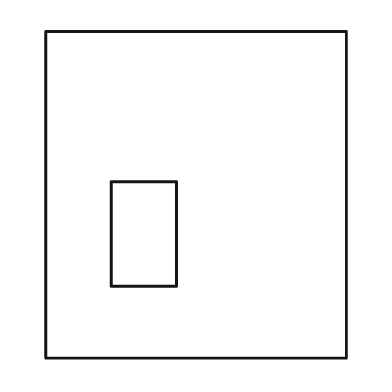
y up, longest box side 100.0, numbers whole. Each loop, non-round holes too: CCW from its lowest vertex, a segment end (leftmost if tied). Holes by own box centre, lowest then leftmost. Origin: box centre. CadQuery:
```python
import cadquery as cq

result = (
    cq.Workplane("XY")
    .moveTo(-46.0, -50.0)
    .lineTo(46.0, -50.0)
    .lineTo(46.0, 50.0)
    .lineTo(-46.0, 50.0)
    .close()
    .moveTo(-26.0, -28.0)
    .lineTo(-6.0, -28.0)
    .lineTo(-6.0, 4.0)
    .lineTo(-26.0, 4.0)
    .close()
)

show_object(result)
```